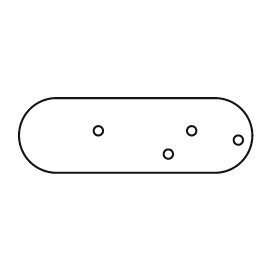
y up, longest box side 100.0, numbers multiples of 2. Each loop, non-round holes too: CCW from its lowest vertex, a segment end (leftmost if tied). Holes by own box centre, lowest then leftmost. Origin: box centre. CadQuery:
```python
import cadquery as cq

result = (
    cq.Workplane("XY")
    .moveTo(-34.0, -16.0)
    .lineTo(34.0, -16.0)
    .threePointArc((50.0, 0.0), (34.0, 16.0))
    .lineTo(-34.0, 16.0)
    .threePointArc((-50.0, 0.0), (-34.0, -16.0))
    .close()
    .moveTo(14.0, -8.0)
    .circle(2.0)
    .moveTo(44.0, -2.0)
    .circle(2.0)
    .moveTo(-16.0, 2.0)
    .circle(2.0)
    .moveTo(24.0, 2.0)
    .circle(2.0)
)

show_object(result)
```